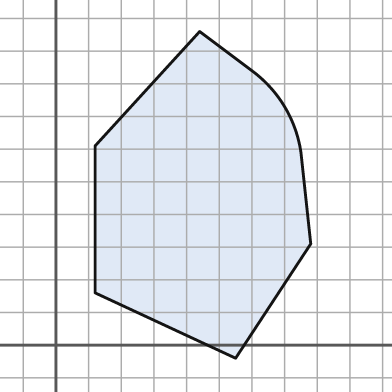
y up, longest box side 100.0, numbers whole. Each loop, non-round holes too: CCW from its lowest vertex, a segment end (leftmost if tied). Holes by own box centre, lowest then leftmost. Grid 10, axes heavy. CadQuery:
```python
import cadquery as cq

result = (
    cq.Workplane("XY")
    .moveTo(55.0, -4.0)
    .lineTo(78.0, 31.0)
    .lineTo(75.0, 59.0)
    .threePointArc((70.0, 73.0), (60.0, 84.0))
    .lineTo(44.0, 96.0)
    .lineTo(12.0, 61.0)
    .lineTo(12.0, 16.0)
    .close()
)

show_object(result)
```